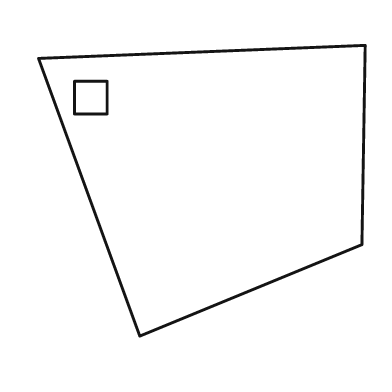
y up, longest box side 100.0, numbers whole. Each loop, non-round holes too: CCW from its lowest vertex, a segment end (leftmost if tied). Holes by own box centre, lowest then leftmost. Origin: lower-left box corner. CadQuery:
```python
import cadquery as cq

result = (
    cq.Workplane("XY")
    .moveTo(31.0, 0.0)
    .lineTo(99.0, 28.0)
    .lineTo(100.0, 89.0)
    .lineTo(0.0, 85.0)
    .close()
    .moveTo(11.0, 68.0)
    .lineTo(21.0, 68.0)
    .lineTo(21.0, 78.0)
    .lineTo(11.0, 78.0)
    .close()
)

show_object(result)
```